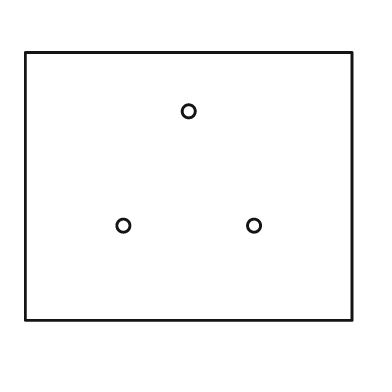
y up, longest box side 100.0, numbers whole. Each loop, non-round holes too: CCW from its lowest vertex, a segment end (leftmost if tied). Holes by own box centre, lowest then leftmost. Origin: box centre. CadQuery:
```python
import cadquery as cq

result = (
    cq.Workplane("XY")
    .moveTo(-50.0, -41.0)
    .lineTo(50.0, -41.0)
    .lineTo(50.0, 41.0)
    .lineTo(-50.0, 41.0)
    .close()
    .moveTo(-20.0, -12.0)
    .circle(2.0)
    .moveTo(20.0, -12.0)
    .circle(2.0)
    .moveTo(0.0, 23.0)
    .circle(2.0)
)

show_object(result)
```